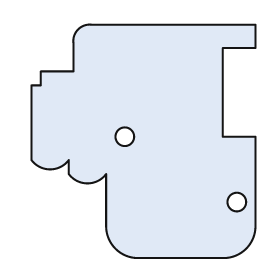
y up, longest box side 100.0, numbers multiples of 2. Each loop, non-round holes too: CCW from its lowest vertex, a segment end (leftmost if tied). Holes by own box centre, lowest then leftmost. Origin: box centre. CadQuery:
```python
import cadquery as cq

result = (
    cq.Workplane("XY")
    .moveTo(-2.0, -50.0)
    .lineTo(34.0, -50.0)
    .threePointArc((44.0, -46.0), (48.0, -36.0))
    .lineTo(48.0, 2.0)
    .lineTo(34.0, 2.0)
    .lineTo(34.0, 40.0)
    .lineTo(48.0, 40.0)
    .lineTo(48.0, 50.0)
    .lineTo(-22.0, 50.0)
    .threePointArc((-28.0, 48.0), (-30.0, 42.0))
    .lineTo(-30.0, 30.0)
    .lineTo(-44.0, 30.0)
    .lineTo(-44.0, 24.0)
    .lineTo(-48.0, 24.0)
    .lineTo(-48.0, -8.0)
    .threePointArc((-40.0, -12.0), (-32.0, -8.0))
    .lineTo(-32.0, -14.0)
    .threePointArc((-24.0, -18.0), (-16.0, -14.0))
    .lineTo(-16.0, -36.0)
    .threePointArc((-12.0, -46.0), (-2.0, -50.0))
    .close()
    .moveTo(40.0, -26.0)
    .circle(4.0)
    .moveTo(-8.0, 2.0)
    .circle(4.0)
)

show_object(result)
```